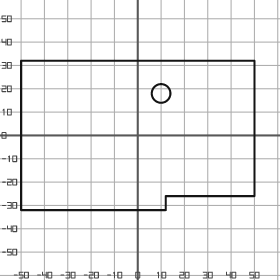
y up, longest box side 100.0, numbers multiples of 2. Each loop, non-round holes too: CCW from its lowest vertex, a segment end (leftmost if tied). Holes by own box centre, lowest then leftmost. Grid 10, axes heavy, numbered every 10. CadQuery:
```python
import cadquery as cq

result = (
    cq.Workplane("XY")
    .moveTo(-50.0, -32.0)
    .lineTo(12.0, -32.0)
    .lineTo(12.0, -26.0)
    .lineTo(50.0, -26.0)
    .lineTo(50.0, 32.0)
    .lineTo(-50.0, 32.0)
    .close()
    .moveTo(10.0, 18.0)
    .circle(4.0)
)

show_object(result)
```